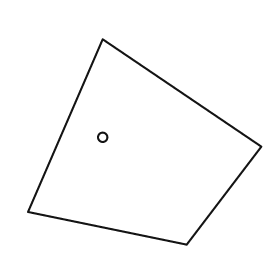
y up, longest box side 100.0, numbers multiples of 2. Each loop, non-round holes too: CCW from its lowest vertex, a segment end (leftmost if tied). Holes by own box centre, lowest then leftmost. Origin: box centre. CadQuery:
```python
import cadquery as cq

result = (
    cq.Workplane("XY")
    .moveTo(18.0, -44.0)
    .lineTo(50.0, -2.0)
    .lineTo(-18.0, 44.0)
    .lineTo(-50.0, -30.0)
    .close()
    .moveTo(-18.0, 2.0)
    .circle(2.0)
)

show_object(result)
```